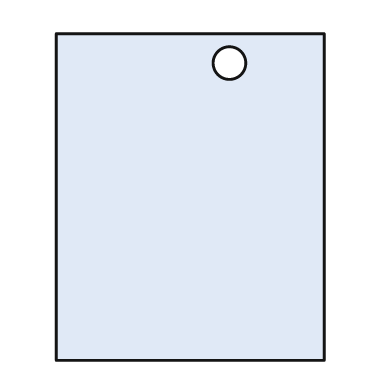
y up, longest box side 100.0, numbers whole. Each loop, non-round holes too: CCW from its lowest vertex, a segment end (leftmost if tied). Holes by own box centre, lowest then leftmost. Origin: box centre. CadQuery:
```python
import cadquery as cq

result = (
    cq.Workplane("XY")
    .moveTo(-41.0, -50.0)
    .lineTo(41.0, -50.0)
    .lineTo(41.0, 50.0)
    .lineTo(-41.0, 50.0)
    .close()
    .moveTo(12.0, 41.0)
    .circle(5.0)
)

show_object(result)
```